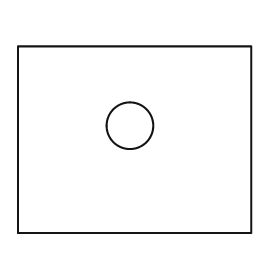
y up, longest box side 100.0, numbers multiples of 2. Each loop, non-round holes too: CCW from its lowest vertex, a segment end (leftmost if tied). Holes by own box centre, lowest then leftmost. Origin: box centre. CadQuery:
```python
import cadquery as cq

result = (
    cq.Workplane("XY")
    .moveTo(-50.0, -40.0)
    .lineTo(50.0, -40.0)
    .lineTo(50.0, 40.0)
    .lineTo(-50.0, 40.0)
    .close()
    .moveTo(-2.0, 6.0)
    .circle(10.0)
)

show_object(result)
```